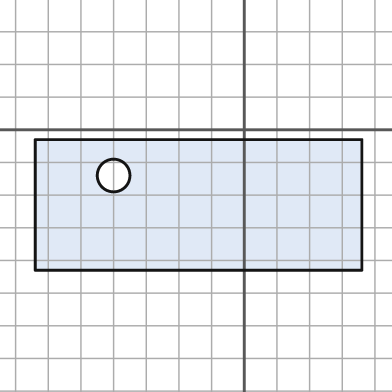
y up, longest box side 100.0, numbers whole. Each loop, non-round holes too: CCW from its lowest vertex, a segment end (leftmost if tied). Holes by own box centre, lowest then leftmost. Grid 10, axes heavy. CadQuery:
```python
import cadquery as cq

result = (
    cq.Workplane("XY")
    .moveTo(-64.0, -43.0)
    .lineTo(36.0, -43.0)
    .lineTo(36.0, -3.0)
    .lineTo(-64.0, -3.0)
    .close()
    .moveTo(-40.0, -14.0)
    .circle(5.0)
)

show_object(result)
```